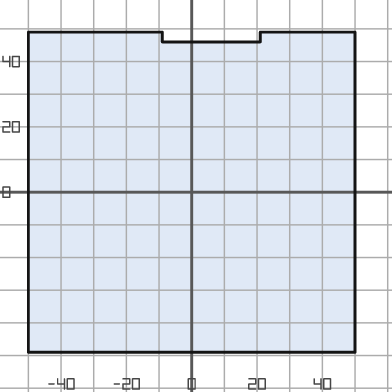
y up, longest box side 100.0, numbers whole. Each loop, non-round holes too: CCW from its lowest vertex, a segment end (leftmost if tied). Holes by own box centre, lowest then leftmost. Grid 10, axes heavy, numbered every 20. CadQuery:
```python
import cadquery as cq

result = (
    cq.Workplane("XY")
    .moveTo(-50.0, -49.0)
    .lineTo(50.0, -49.0)
    .lineTo(50.0, 49.0)
    .lineTo(21.0, 49.0)
    .lineTo(21.0, 46.0)
    .lineTo(-9.0, 46.0)
    .lineTo(-9.0, 49.0)
    .lineTo(-50.0, 49.0)
    .close()
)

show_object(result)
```